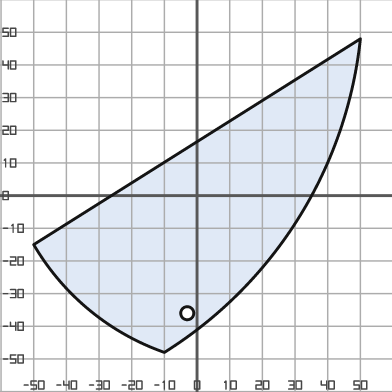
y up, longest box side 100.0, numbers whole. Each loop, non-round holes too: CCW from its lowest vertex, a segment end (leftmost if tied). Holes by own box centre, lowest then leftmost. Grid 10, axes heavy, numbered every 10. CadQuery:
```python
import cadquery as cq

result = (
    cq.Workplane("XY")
    .moveTo(-10.0, -48.0)
    .threePointArc((31.0, -7.0), (50.0, 48.0))
    .lineTo(-50.0, -15.0)
    .threePointArc((-33.0, -35.0), (-10.0, -48.0))
    .close()
    .moveTo(-3.0, -36.0)
    .circle(2.0)
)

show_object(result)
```